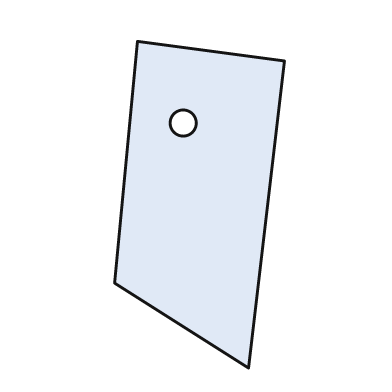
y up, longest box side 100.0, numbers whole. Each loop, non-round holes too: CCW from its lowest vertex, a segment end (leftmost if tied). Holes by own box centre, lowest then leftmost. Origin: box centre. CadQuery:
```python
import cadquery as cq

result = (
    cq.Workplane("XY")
    .moveTo(15.0, -50.0)
    .lineTo(26.0, 44.0)
    .lineTo(-19.0, 50.0)
    .lineTo(-26.0, -24.0)
    .close()
    .moveTo(-5.0, 25.0)
    .circle(4.0)
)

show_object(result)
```